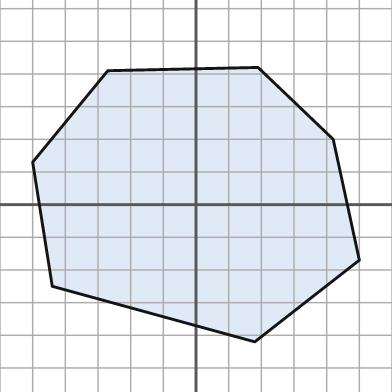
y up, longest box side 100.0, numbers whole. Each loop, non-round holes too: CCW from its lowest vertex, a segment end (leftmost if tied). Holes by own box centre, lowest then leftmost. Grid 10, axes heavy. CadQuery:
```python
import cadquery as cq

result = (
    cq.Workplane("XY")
    .moveTo(18.0, -42.0)
    .lineTo(50.0, -17.0)
    .lineTo(42.0, 20.0)
    .lineTo(19.0, 42.0)
    .lineTo(-27.0, 41.0)
    .lineTo(-50.0, 13.0)
    .lineTo(-44.0, -25.0)
    .close()
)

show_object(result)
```